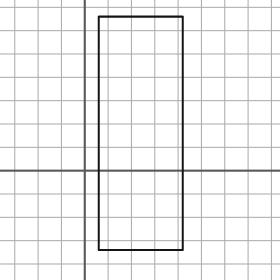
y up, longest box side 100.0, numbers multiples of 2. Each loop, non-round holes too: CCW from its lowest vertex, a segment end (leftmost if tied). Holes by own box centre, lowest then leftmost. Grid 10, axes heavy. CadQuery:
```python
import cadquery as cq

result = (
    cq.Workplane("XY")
    .moveTo(6.0, -34.0)
    .lineTo(42.0, -34.0)
    .lineTo(42.0, 66.0)
    .lineTo(6.0, 66.0)
    .close()
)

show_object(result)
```